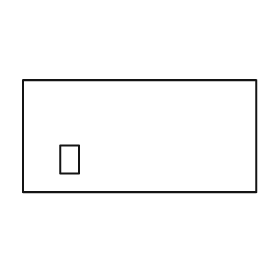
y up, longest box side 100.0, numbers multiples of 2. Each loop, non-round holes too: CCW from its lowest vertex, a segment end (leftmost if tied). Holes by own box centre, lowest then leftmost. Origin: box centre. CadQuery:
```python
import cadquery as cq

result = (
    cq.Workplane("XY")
    .moveTo(-50.0, -24.0)
    .lineTo(50.0, -24.0)
    .lineTo(50.0, 24.0)
    .lineTo(-50.0, 24.0)
    .close()
    .moveTo(-34.0, -16.0)
    .lineTo(-26.0, -16.0)
    .lineTo(-26.0, -4.0)
    .lineTo(-34.0, -4.0)
    .close()
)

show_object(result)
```